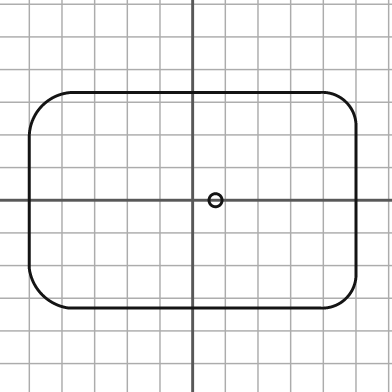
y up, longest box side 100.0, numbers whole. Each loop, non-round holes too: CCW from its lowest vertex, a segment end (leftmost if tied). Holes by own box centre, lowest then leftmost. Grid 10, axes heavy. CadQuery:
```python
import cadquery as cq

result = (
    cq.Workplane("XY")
    .moveTo(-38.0, -33.0)
    .lineTo(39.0, -33.0)
    .threePointArc((47.0, -30.0), (50.0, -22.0))
    .lineTo(50.0, 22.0)
    .threePointArc((47.0, 30.0), (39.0, 33.0))
    .lineTo(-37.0, 33.0)
    .threePointArc((-46.0, 29.0), (-50.0, 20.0))
    .lineTo(-50.0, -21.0)
    .threePointArc((-46.0, -29.0), (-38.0, -33.0))
    .close()
    .moveTo(7.0, 0.0)
    .circle(2.0)
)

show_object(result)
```